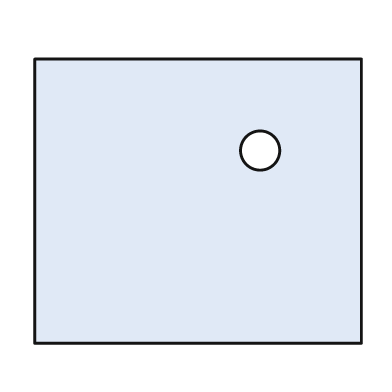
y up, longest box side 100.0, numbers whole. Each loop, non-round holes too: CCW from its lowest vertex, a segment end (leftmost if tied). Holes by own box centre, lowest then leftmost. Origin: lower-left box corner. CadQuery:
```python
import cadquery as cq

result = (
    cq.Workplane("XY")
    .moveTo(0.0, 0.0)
    .lineTo(100.0, 0.0)
    .lineTo(100.0, 87.0)
    .lineTo(0.0, 87.0)
    .close()
    .moveTo(69.0, 59.0)
    .circle(6.0)
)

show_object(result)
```